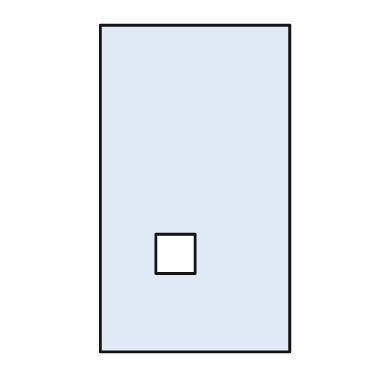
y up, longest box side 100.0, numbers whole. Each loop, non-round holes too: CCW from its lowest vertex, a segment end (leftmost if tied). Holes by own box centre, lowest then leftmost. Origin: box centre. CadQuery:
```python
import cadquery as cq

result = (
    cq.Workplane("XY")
    .moveTo(-29.0, -50.0)
    .lineTo(29.0, -50.0)
    .lineTo(29.0, 50.0)
    .lineTo(-29.0, 50.0)
    .close()
    .moveTo(-12.0, -26.0)
    .lineTo(0.0, -26.0)
    .lineTo(0.0, -14.0)
    .lineTo(-12.0, -14.0)
    .close()
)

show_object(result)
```